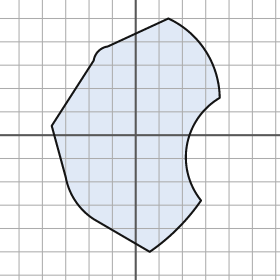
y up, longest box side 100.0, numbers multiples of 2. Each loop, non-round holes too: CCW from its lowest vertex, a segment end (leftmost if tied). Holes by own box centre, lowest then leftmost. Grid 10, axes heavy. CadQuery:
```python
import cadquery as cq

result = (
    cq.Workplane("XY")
    .moveTo(6.0, -50.0)
    .threePointArc((18.0, -40.0), (28.0, -28.0))
    .threePointArc((22.0, -4.0), (36.0, 16.0))
    .threePointArc((30.0, 36.0), (14.0, 50.0))
    .lineTo(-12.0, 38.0)
    .threePointArc((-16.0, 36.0), (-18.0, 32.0))
    .lineTo(-36.0, 4.0)
    .lineTo(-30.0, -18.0)
    .threePointArc((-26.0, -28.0), (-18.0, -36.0))
    .close()
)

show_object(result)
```